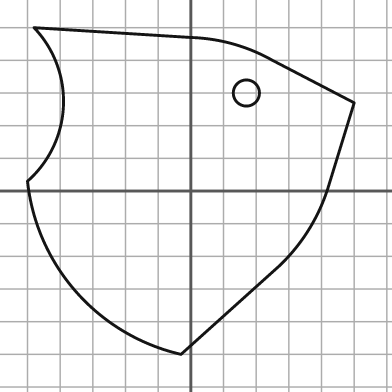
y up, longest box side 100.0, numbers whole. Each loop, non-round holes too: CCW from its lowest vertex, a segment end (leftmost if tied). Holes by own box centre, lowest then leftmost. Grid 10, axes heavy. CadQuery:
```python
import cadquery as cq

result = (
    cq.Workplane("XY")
    .moveTo(-3.0, -50.0)
    .lineTo(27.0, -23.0)
    .threePointArc((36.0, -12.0), (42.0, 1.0))
    .lineTo(50.0, 27.0)
    .lineTo(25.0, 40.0)
    .threePointArc((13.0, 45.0), (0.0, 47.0))
    .lineTo(-48.0, 50.0)
    .threePointArc((-39.0, 26.0), (-50.0, 3.0))
    .threePointArc((-35.0, -31.0), (-3.0, -50.0))
    .close()
    .moveTo(17.0, 30.0)
    .circle(4.0)
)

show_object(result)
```